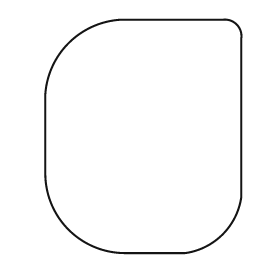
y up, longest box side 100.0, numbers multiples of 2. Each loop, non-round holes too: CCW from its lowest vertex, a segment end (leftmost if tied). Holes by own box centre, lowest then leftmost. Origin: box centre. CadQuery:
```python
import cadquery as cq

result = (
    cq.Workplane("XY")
    .moveTo(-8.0, -50.0)
    .lineTo(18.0, -50.0)
    .threePointArc((34.0, -42.0), (42.0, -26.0))
    .lineTo(42.0, 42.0)
    .threePointArc((40.0, 48.0), (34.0, 50.0))
    .lineTo(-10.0, 50.0)
    .threePointArc((-32.0, 40.0), (-42.0, 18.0))
    .lineTo(-42.0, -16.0)
    .threePointArc((-32.0, -40.0), (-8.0, -50.0))
    .close()
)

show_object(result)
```